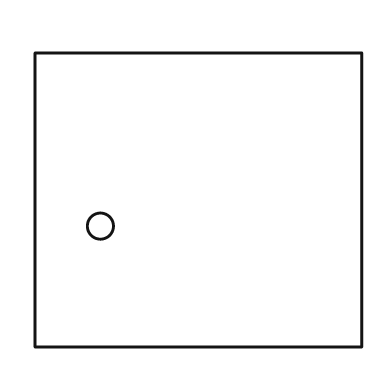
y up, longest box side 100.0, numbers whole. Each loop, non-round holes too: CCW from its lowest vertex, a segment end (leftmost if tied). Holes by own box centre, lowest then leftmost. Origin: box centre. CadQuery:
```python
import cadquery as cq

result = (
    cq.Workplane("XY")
    .moveTo(-50.0, -45.0)
    .lineTo(50.0, -45.0)
    .lineTo(50.0, 45.0)
    .lineTo(-50.0, 45.0)
    .close()
    .moveTo(-30.0, -8.0)
    .circle(4.0)
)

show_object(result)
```